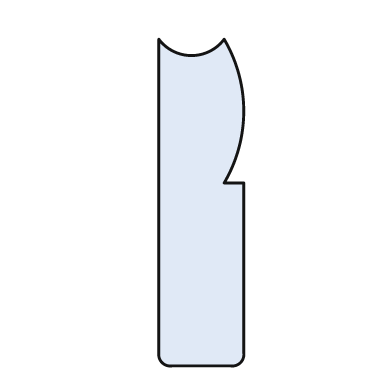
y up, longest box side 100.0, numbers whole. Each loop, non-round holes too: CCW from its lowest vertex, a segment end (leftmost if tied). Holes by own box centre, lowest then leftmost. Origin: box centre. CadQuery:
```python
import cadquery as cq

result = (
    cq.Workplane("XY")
    .moveTo(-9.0, -50.0)
    .lineTo(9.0, -50.0)
    .threePointArc((12.0, -49.0), (13.0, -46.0))
    .lineTo(13.0, 6.0)
    .lineTo(7.0, 6.0)
    .threePointArc((13.0, 28.0), (7.0, 50.0))
    .threePointArc((-3.0, 45.0), (-13.0, 50.0))
    .lineTo(-13.0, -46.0)
    .threePointArc((-12.0, -49.0), (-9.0, -50.0))
    .close()
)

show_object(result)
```